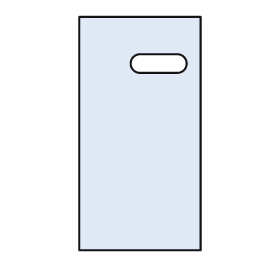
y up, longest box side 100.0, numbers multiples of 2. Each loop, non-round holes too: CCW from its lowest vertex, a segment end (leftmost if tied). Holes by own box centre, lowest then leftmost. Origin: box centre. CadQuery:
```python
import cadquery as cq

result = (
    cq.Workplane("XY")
    .moveTo(-26.0, -50.0)
    .lineTo(26.0, -50.0)
    .lineTo(26.0, 50.0)
    .lineTo(-26.0, 50.0)
    .close()
    .moveTo(0.0, 26.0)
    .lineTo(16.0, 26.0)
    .threePointArc((20.0, 30.0), (16.0, 34.0))
    .lineTo(0.0, 34.0)
    .threePointArc((-4.0, 30.0), (0.0, 26.0))
    .close()
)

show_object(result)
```